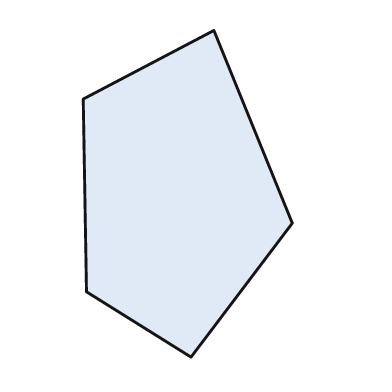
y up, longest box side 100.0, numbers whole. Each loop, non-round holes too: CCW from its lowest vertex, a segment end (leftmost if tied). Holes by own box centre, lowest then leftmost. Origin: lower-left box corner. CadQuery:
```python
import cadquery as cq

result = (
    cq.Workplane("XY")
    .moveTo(33.0, 0.0)
    .lineTo(64.0, 41.0)
    .lineTo(40.0, 100.0)
    .lineTo(0.0, 79.0)
    .lineTo(1.0, 20.0)
    .close()
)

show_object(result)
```